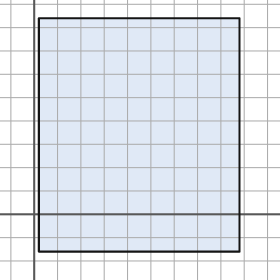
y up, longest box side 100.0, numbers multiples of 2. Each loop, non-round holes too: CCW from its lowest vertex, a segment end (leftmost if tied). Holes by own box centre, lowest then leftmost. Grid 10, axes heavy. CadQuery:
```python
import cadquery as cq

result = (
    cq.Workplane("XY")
    .moveTo(2.0, -16.0)
    .lineTo(88.0, -16.0)
    .lineTo(88.0, 84.0)
    .lineTo(2.0, 84.0)
    .close()
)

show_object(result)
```